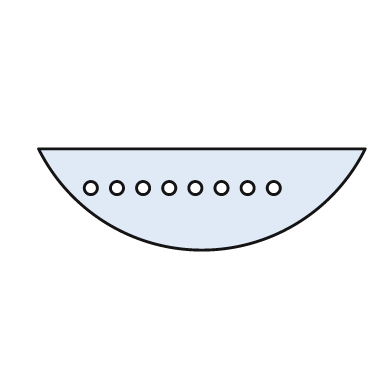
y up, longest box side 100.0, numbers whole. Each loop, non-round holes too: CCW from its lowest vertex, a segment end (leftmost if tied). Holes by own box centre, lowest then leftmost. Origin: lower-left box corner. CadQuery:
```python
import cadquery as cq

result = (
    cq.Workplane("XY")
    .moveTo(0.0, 31.0)
    .threePointArc((50.0, 0.0), (100.0, 31.0))
    .close()
    .moveTo(16.0, 19.0)
    .circle(2.0)
    .moveTo(24.0, 19.0)
    .circle(2.0)
    .moveTo(32.0, 19.0)
    .circle(2.0)
    .moveTo(40.0, 19.0)
    .circle(2.0)
    .moveTo(48.0, 19.0)
    .circle(2.0)
    .moveTo(56.0, 19.0)
    .circle(2.0)
    .moveTo(64.0, 19.0)
    .circle(2.0)
    .moveTo(72.0, 19.0)
    .circle(2.0)
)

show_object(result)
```